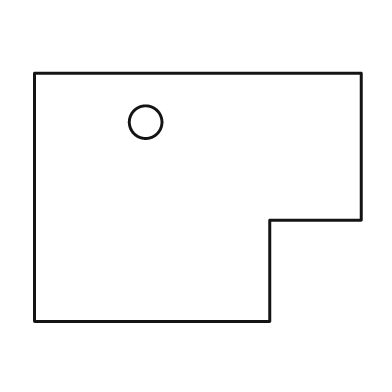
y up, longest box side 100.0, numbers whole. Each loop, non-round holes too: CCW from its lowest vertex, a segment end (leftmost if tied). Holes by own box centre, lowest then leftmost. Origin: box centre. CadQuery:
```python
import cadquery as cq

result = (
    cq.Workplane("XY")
    .moveTo(-50.0, -38.0)
    .lineTo(22.0, -38.0)
    .lineTo(22.0, -7.0)
    .lineTo(50.0, -7.0)
    .lineTo(50.0, 38.0)
    .lineTo(-50.0, 38.0)
    .close()
    .moveTo(-16.0, 23.0)
    .circle(5.0)
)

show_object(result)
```